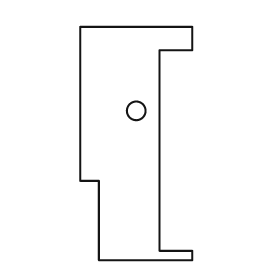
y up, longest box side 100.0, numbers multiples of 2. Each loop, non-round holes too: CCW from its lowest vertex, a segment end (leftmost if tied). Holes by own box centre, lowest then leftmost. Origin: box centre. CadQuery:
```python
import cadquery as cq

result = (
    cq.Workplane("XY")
    .moveTo(-16.0, -50.0)
    .lineTo(24.0, -50.0)
    .lineTo(24.0, -46.0)
    .lineTo(10.0, -46.0)
    .lineTo(10.0, 40.0)
    .lineTo(24.0, 40.0)
    .lineTo(24.0, 50.0)
    .lineTo(-24.0, 50.0)
    .lineTo(-24.0, -16.0)
    .lineTo(-16.0, -16.0)
    .close()
    .moveTo(0.0, 14.0)
    .circle(4.0)
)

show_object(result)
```